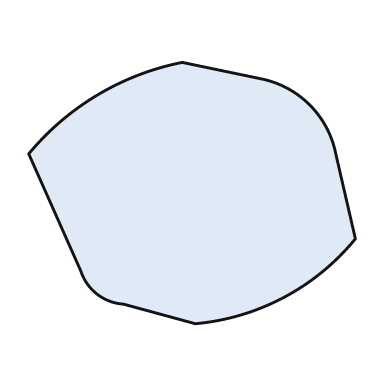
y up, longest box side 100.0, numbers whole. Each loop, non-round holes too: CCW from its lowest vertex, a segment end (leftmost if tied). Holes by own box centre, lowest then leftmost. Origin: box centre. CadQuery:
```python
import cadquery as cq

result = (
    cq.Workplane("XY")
    .moveTo(1.0, -40.0)
    .threePointArc((28.0, -32.0), (50.0, -14.0))
    .lineTo(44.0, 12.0)
    .threePointArc((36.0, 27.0), (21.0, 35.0))
    .lineTo(-3.0, 40.0)
    .threePointArc((-29.0, 30.0), (-50.0, 12.0))
    .lineTo(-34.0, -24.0)
    .threePointArc((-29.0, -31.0), (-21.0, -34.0))
    .close()
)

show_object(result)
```